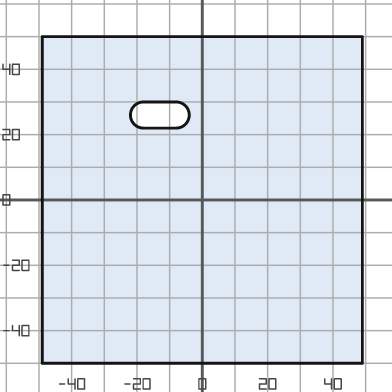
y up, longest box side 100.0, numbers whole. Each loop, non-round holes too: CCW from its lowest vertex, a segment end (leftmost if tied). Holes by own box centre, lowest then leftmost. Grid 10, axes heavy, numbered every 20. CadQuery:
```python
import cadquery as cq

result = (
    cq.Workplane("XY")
    .moveTo(-49.0, -50.0)
    .lineTo(49.0, -50.0)
    .lineTo(49.0, 50.0)
    .lineTo(-49.0, 50.0)
    .close()
    .moveTo(-18.0, 22.0)
    .lineTo(-8.0, 22.0)
    .threePointArc((-4.0, 26.0), (-8.0, 30.0))
    .lineTo(-18.0, 30.0)
    .threePointArc((-22.0, 26.0), (-18.0, 22.0))
    .close()
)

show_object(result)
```